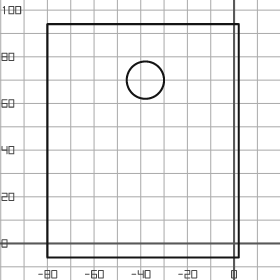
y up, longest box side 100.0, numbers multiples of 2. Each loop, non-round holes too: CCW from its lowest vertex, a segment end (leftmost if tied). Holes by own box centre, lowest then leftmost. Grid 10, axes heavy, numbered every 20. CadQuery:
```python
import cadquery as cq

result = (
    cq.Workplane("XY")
    .moveTo(-80.0, -6.0)
    .lineTo(2.0, -6.0)
    .lineTo(2.0, 94.0)
    .lineTo(-80.0, 94.0)
    .close()
    .moveTo(-38.0, 70.0)
    .circle(8.0)
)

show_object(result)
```